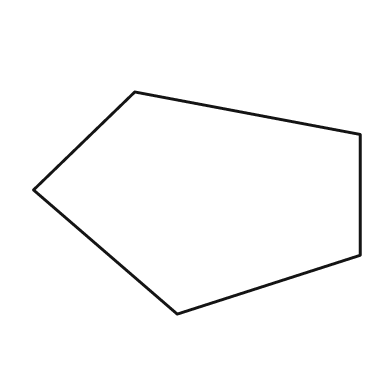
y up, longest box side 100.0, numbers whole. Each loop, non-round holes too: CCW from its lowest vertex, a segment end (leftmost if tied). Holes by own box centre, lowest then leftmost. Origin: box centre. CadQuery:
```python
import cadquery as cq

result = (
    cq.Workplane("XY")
    .moveTo(-6.0, -34.0)
    .lineTo(50.0, -16.0)
    .lineTo(50.0, 21.0)
    .lineTo(-19.0, 34.0)
    .lineTo(-50.0, 4.0)
    .close()
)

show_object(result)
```